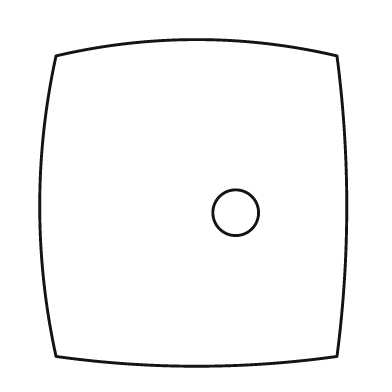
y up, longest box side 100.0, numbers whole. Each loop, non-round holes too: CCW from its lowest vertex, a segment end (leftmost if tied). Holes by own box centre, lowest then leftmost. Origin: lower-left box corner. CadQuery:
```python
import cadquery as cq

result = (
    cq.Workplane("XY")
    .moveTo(5.0, 3.0)
    .threePointArc((48.0, 0.0), (91.0, 3.0))
    .threePointArc((94.0, 49.0), (91.0, 95.0))
    .threePointArc((48.0, 100.0), (5.0, 95.0))
    .threePointArc((0.0, 49.0), (5.0, 3.0))
    .close()
    .moveTo(60.0, 47.0)
    .circle(7.0)
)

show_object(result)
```